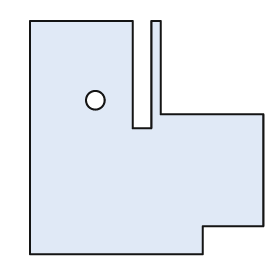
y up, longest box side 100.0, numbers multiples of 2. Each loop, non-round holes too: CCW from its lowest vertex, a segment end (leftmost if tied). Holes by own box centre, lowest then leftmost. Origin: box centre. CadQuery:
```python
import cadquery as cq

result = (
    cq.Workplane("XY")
    .moveTo(-50.0, -50.0)
    .lineTo(24.0, -50.0)
    .lineTo(24.0, -38.0)
    .lineTo(50.0, -38.0)
    .lineTo(50.0, 10.0)
    .lineTo(6.0, 10.0)
    .lineTo(6.0, 50.0)
    .lineTo(2.0, 50.0)
    .lineTo(2.0, 4.0)
    .lineTo(-6.0, 4.0)
    .lineTo(-6.0, 50.0)
    .lineTo(-50.0, 50.0)
    .close()
    .moveTo(-22.0, 16.0)
    .circle(4.0)
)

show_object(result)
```